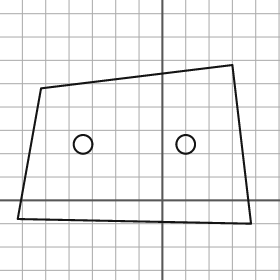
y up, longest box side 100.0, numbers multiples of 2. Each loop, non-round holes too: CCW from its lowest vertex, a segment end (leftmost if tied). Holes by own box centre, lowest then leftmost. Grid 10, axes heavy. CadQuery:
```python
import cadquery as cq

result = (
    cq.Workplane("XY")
    .moveTo(38.0, -10.0)
    .lineTo(30.0, 58.0)
    .lineTo(-52.0, 48.0)
    .lineTo(-62.0, -8.0)
    .close()
    .moveTo(-34.0, 24.0)
    .circle(4.0)
    .moveTo(10.0, 24.0)
    .circle(4.0)
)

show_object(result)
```